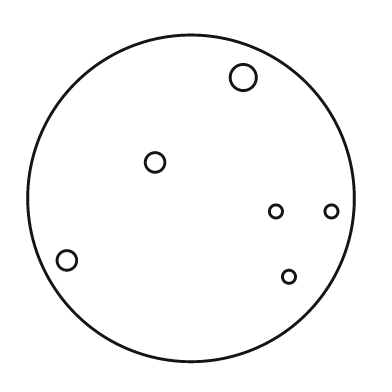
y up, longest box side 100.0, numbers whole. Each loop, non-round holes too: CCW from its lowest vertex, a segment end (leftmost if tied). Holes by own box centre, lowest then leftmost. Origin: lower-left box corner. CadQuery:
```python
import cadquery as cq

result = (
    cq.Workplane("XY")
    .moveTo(50.0, 50.0)
    .circle(50.0)
    .moveTo(80.0, 26.0)
    .circle(2.0)
    .moveTo(12.0, 31.0)
    .circle(3.0)
    .moveTo(76.0, 46.0)
    .circle(2.0)
    .moveTo(93.0, 46.0)
    .circle(2.0)
    .moveTo(39.0, 61.0)
    .circle(3.0)
    .moveTo(66.0, 87.0)
    .circle(4.0)
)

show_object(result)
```